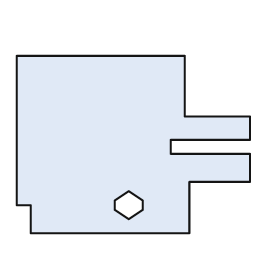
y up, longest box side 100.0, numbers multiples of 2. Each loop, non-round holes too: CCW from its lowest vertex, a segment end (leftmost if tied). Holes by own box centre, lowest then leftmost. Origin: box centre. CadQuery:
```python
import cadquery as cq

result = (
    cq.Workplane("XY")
    .moveTo(-44.0, -38.0)
    .lineTo(24.0, -38.0)
    .lineTo(24.0, -16.0)
    .lineTo(50.0, -16.0)
    .lineTo(50.0, -4.0)
    .lineTo(16.0, -4.0)
    .lineTo(16.0, 2.0)
    .lineTo(50.0, 2.0)
    .lineTo(50.0, 12.0)
    .lineTo(22.0, 12.0)
    .lineTo(22.0, 38.0)
    .lineTo(-50.0, 38.0)
    .lineTo(-50.0, -26.0)
    .lineTo(-44.0, -26.0)
    .close()
    .moveTo(-2.0, -32.0)
    .lineTo(4.0, -28.0)
    .lineTo(4.0, -24.0)
    .lineTo(-2.0, -20.0)
    .lineTo(-8.0, -24.0)
    .lineTo(-8.0, -28.0)
    .close()
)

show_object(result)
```